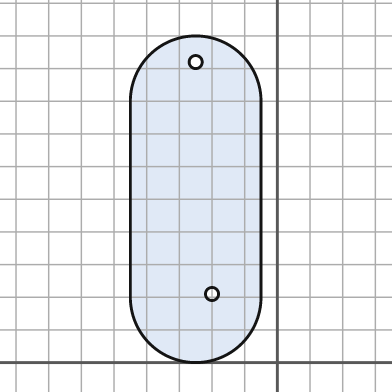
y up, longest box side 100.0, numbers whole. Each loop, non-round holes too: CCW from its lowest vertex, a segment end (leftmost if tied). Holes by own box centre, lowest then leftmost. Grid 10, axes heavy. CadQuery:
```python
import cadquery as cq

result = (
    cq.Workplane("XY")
    .moveTo(-45.0, 20.0)
    .threePointArc((-25.0, 0.0), (-5.0, 20.0))
    .lineTo(-5.0, 80.0)
    .threePointArc((-25.0, 100.0), (-45.0, 80.0))
    .close()
    .moveTo(-20.0, 21.0)
    .circle(2.0)
    .moveTo(-25.0, 92.0)
    .circle(2.0)
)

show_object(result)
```